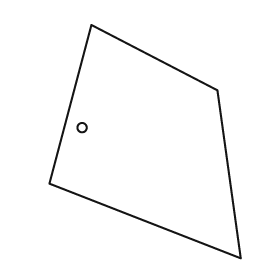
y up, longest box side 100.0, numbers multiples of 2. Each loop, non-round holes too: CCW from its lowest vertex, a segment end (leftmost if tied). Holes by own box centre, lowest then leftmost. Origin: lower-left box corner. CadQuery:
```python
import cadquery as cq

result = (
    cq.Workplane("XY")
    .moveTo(82.0, 0.0)
    .lineTo(72.0, 72.0)
    .lineTo(18.0, 100.0)
    .lineTo(0.0, 32.0)
    .close()
    .moveTo(14.0, 56.0)
    .circle(2.0)
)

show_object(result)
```